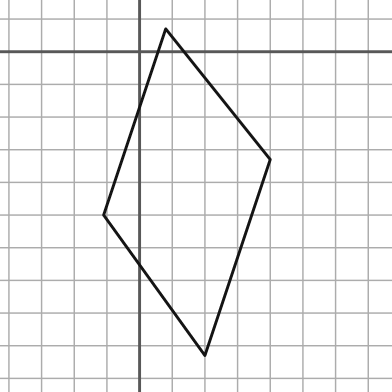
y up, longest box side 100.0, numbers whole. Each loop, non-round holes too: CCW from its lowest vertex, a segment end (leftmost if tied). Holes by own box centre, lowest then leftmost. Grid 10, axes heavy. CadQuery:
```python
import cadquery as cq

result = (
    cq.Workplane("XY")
    .moveTo(20.0, -93.0)
    .lineTo(40.0, -33.0)
    .lineTo(8.0, 7.0)
    .lineTo(-11.0, -50.0)
    .close()
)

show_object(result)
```